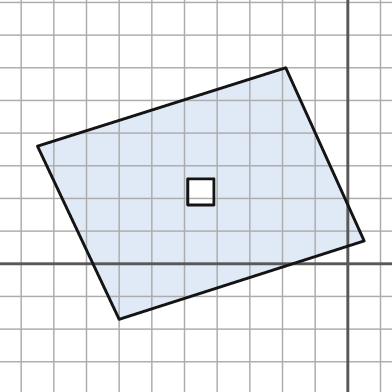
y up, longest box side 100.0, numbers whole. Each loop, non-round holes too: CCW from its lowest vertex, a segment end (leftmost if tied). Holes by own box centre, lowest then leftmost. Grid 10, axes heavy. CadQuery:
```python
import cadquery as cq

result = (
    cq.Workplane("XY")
    .moveTo(-70.0, -17.0)
    .lineTo(5.0, 7.0)
    .lineTo(-19.0, 60.0)
    .lineTo(-95.0, 36.0)
    .close()
    .moveTo(-49.0, 18.0)
    .lineTo(-41.0, 18.0)
    .lineTo(-41.0, 26.0)
    .lineTo(-49.0, 26.0)
    .close()
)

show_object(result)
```